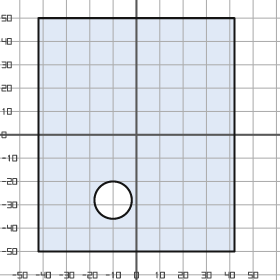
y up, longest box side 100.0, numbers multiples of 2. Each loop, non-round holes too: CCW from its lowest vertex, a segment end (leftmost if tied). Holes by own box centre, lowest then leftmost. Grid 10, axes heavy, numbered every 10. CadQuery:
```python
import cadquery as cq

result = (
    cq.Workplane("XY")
    .moveTo(-42.0, -50.0)
    .lineTo(42.0, -50.0)
    .lineTo(42.0, 50.0)
    .lineTo(-42.0, 50.0)
    .close()
    .moveTo(-10.0, -28.0)
    .circle(8.0)
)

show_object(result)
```